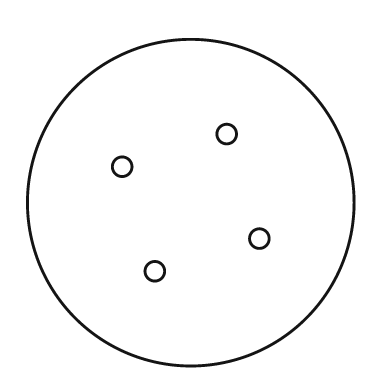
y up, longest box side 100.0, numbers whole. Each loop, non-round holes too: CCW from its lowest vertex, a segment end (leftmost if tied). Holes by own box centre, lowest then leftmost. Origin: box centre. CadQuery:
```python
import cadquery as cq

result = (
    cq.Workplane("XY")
    .moveTo(0.0, 0.0)
    .circle(50.0)
    .moveTo(-11.0, -21.0)
    .circle(3.0)
    .moveTo(21.0, -11.0)
    .circle(3.0)
    .moveTo(-21.0, 11.0)
    .circle(3.0)
    .moveTo(11.0, 21.0)
    .circle(3.0)
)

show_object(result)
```